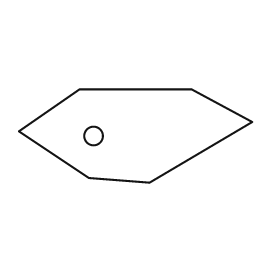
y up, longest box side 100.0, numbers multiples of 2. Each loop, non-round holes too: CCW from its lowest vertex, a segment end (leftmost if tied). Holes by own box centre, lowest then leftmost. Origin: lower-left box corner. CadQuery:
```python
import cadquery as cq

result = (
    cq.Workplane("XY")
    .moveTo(56.0, 0.0)
    .lineTo(100.0, 26.0)
    .lineTo(74.0, 40.0)
    .lineTo(26.0, 40.0)
    .lineTo(0.0, 22.0)
    .lineTo(30.0, 2.0)
    .close()
    .moveTo(32.0, 20.0)
    .circle(4.0)
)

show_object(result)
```